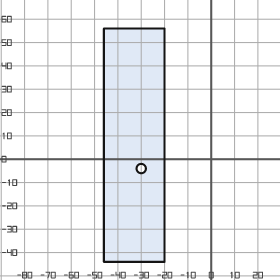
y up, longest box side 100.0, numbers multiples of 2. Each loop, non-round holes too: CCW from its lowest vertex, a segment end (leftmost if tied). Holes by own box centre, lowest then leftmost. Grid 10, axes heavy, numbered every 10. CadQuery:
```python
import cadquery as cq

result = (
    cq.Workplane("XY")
    .moveTo(-46.0, -44.0)
    .lineTo(-20.0, -44.0)
    .lineTo(-20.0, 56.0)
    .lineTo(-46.0, 56.0)
    .close()
    .moveTo(-30.0, -4.0)
    .circle(2.0)
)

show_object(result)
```